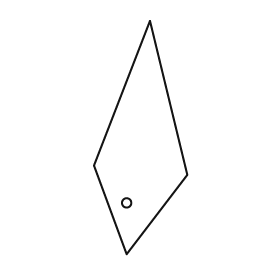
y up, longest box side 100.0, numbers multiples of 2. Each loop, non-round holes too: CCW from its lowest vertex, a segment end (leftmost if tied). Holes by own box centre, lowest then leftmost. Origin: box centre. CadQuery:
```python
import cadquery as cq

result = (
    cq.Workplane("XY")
    .moveTo(-6.0, -50.0)
    .lineTo(20.0, -16.0)
    .lineTo(4.0, 50.0)
    .lineTo(-20.0, -12.0)
    .close()
    .moveTo(-6.0, -28.0)
    .circle(2.0)
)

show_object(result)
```